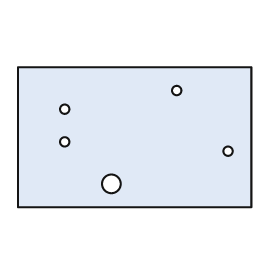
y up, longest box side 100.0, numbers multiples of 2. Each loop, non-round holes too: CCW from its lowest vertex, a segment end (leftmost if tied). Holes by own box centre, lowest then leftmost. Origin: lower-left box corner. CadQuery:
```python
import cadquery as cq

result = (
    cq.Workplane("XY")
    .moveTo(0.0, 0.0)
    .lineTo(100.0, 0.0)
    .lineTo(100.0, 60.0)
    .lineTo(0.0, 60.0)
    .close()
    .moveTo(40.0, 10.0)
    .circle(4.0)
    .moveTo(90.0, 24.0)
    .circle(2.0)
    .moveTo(20.0, 28.0)
    .circle(2.0)
    .moveTo(20.0, 42.0)
    .circle(2.0)
    .moveTo(68.0, 50.0)
    .circle(2.0)
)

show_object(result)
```